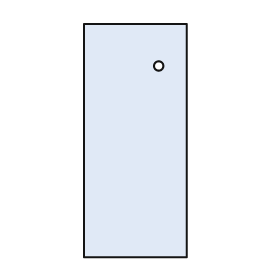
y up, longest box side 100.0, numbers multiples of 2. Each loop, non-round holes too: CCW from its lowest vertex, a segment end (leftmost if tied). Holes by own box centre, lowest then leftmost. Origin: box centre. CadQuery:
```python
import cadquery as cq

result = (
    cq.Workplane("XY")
    .moveTo(-22.0, -50.0)
    .lineTo(22.0, -50.0)
    .lineTo(22.0, 50.0)
    .lineTo(-22.0, 50.0)
    .close()
    .moveTo(10.0, 32.0)
    .circle(2.0)
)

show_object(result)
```